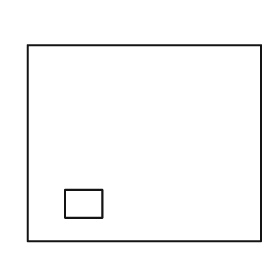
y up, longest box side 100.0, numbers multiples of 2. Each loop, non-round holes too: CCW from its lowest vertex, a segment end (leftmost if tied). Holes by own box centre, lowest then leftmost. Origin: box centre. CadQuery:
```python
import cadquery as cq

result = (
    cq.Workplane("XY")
    .moveTo(-50.0, -42.0)
    .lineTo(50.0, -42.0)
    .lineTo(50.0, 42.0)
    .lineTo(-50.0, 42.0)
    .close()
    .moveTo(-34.0, -32.0)
    .lineTo(-18.0, -32.0)
    .lineTo(-18.0, -20.0)
    .lineTo(-34.0, -20.0)
    .close()
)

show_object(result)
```